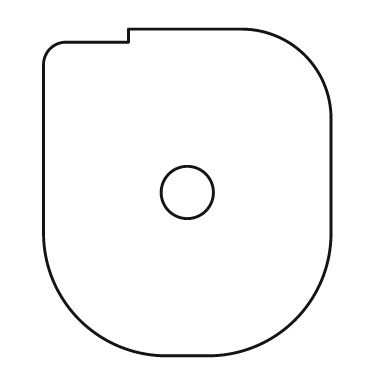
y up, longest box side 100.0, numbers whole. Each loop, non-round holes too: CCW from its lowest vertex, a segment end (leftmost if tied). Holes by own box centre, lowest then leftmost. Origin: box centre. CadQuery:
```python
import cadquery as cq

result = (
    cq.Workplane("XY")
    .moveTo(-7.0, -50.0)
    .lineTo(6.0, -50.0)
    .threePointArc((33.0, -39.0), (44.0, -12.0))
    .lineTo(44.0, 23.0)
    .threePointArc((36.0, 42.0), (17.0, 50.0))
    .lineTo(-18.0, 50.0)
    .lineTo(-18.0, 46.0)
    .lineTo(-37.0, 46.0)
    .threePointArc((-42.0, 44.0), (-44.0, 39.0))
    .lineTo(-44.0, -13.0)
    .threePointArc((-33.0, -39.0), (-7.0, -50.0))
    .close()
    .moveTo(0.0, 0.0)
    .circle(8.0)
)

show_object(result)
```